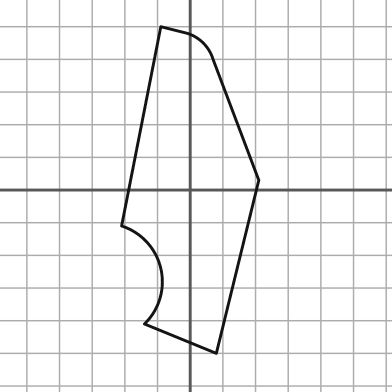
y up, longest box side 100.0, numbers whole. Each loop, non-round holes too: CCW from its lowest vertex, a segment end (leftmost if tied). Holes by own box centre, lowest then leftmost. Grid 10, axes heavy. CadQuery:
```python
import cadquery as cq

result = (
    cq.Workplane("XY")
    .moveTo(8.0, -50.0)
    .lineTo(21.0, 3.0)
    .lineTo(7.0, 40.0)
    .threePointArc((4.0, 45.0), (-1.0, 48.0))
    .lineTo(-9.0, 50.0)
    .lineTo(-21.0, -11.0)
    .threePointArc((-9.0, -24.0), (-14.0, -41.0))
    .close()
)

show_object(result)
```